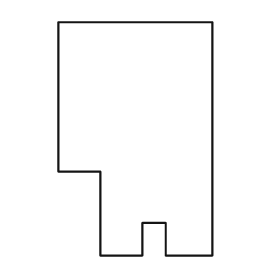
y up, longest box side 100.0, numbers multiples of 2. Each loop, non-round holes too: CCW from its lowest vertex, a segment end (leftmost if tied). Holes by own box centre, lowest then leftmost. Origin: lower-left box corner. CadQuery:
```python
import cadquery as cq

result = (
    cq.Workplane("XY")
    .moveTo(18.0, 0.0)
    .lineTo(36.0, 0.0)
    .lineTo(36.0, 14.0)
    .lineTo(46.0, 14.0)
    .lineTo(46.0, 0.0)
    .lineTo(66.0, 0.0)
    .lineTo(66.0, 100.0)
    .lineTo(0.0, 100.0)
    .lineTo(0.0, 36.0)
    .lineTo(18.0, 36.0)
    .close()
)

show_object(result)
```